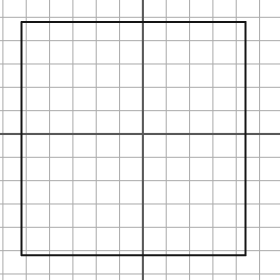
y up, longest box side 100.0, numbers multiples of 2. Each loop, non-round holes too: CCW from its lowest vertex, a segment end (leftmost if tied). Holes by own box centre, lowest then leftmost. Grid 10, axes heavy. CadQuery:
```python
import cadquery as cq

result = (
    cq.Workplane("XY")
    .moveTo(-52.0, -52.0)
    .lineTo(44.0, -52.0)
    .lineTo(44.0, 48.0)
    .lineTo(-52.0, 48.0)
    .close()
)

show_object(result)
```